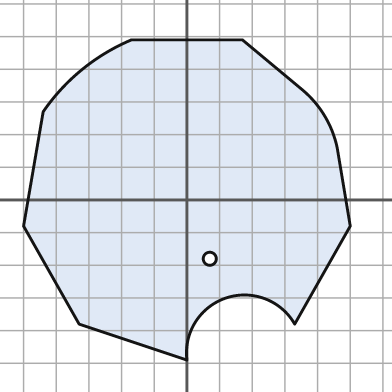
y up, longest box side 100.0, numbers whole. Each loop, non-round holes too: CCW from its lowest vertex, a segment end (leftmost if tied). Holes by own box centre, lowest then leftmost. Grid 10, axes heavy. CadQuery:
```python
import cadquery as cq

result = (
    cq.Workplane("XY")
    .moveTo(0.0, -49.0)
    .threePointArc((12.0, -30.0), (33.0, -38.0))
    .lineTo(50.0, -8.0)
    .lineTo(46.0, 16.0)
    .threePointArc((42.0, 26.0), (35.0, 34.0))
    .lineTo(17.0, 49.0)
    .lineTo(-17.0, 49.0)
    .threePointArc((-32.0, 40.0), (-44.0, 27.0))
    .lineTo(-50.0, -8.0)
    .lineTo(-33.0, -38.0)
    .close()
    .moveTo(7.0, -18.0)
    .circle(2.0)
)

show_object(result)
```